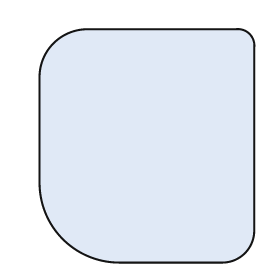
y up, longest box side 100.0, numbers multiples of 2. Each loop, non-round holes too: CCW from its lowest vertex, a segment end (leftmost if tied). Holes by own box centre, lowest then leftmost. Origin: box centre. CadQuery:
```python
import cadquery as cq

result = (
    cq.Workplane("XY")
    .moveTo(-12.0, -50.0)
    .lineTo(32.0, -50.0)
    .threePointArc((42.0, -46.0), (46.0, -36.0))
    .lineTo(46.0, 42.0)
    .threePointArc((44.0, 48.0), (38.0, 50.0))
    .lineTo(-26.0, 50.0)
    .threePointArc((-40.0, 44.0), (-46.0, 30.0))
    .lineTo(-46.0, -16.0)
    .threePointArc((-36.0, -40.0), (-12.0, -50.0))
    .close()
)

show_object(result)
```